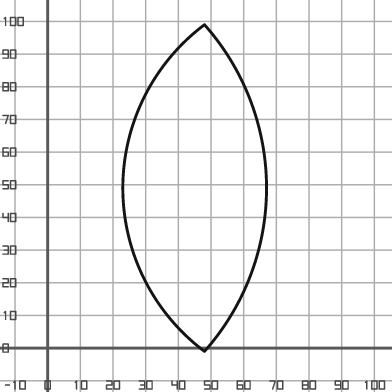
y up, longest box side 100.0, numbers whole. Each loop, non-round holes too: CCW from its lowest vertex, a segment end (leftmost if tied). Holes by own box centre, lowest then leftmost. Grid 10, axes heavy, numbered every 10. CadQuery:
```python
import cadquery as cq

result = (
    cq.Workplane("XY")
    .moveTo(48.0, -1.0)
    .threePointArc((67.0, 49.0), (48.0, 99.0))
    .threePointArc((23.0, 49.0), (48.0, -1.0))
    .close()
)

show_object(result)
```